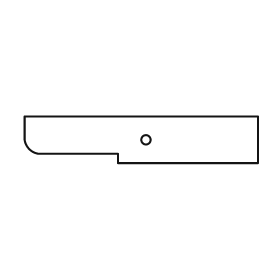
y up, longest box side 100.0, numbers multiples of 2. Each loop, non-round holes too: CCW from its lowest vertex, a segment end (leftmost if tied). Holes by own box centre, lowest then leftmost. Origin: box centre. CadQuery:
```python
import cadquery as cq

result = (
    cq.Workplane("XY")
    .moveTo(-10.0, -10.0)
    .lineTo(50.0, -10.0)
    .lineTo(50.0, 10.0)
    .lineTo(-50.0, 10.0)
    .lineTo(-50.0, 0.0)
    .threePointArc((-48.0, -4.0), (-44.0, -6.0))
    .lineTo(-10.0, -6.0)
    .close()
    .moveTo(2.0, 0.0)
    .circle(2.0)
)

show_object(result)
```